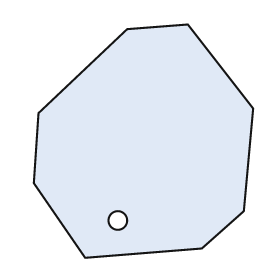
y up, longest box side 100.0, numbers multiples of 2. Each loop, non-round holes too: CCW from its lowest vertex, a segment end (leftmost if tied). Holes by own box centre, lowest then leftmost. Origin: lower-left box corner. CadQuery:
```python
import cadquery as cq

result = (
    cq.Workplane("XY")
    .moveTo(22.0, 0.0)
    .lineTo(72.0, 4.0)
    .lineTo(90.0, 20.0)
    .lineTo(94.0, 64.0)
    .lineTo(66.0, 100.0)
    .lineTo(40.0, 98.0)
    .lineTo(2.0, 62.0)
    .lineTo(0.0, 32.0)
    .close()
    .moveTo(36.0, 16.0)
    .circle(4.0)
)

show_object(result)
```